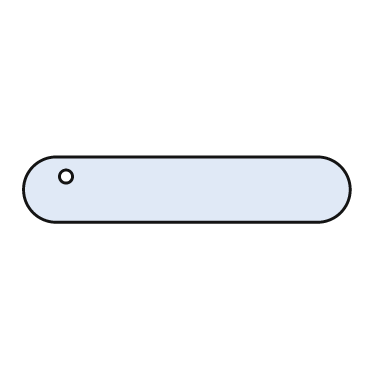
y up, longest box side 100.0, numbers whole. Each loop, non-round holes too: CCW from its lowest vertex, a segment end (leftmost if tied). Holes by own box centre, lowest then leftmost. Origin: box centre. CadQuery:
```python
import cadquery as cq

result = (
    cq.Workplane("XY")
    .moveTo(-40.0, -10.0)
    .lineTo(40.0, -10.0)
    .threePointArc((50.0, 0.0), (40.0, 10.0))
    .lineTo(-40.0, 10.0)
    .threePointArc((-50.0, 0.0), (-40.0, -10.0))
    .close()
    .moveTo(-37.0, 4.0)
    .circle(2.0)
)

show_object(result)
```